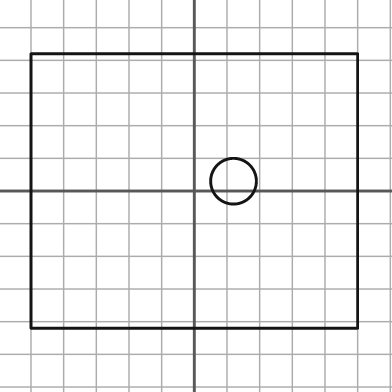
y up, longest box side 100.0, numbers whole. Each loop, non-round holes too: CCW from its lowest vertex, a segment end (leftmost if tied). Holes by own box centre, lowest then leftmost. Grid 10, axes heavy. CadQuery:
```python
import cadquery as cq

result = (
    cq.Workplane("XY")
    .moveTo(-50.0, -42.0)
    .lineTo(50.0, -42.0)
    .lineTo(50.0, 42.0)
    .lineTo(-50.0, 42.0)
    .close()
    .moveTo(12.0, 3.0)
    .circle(7.0)
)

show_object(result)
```